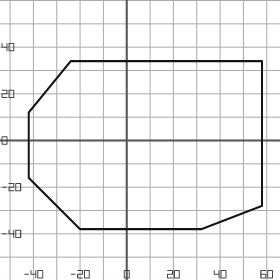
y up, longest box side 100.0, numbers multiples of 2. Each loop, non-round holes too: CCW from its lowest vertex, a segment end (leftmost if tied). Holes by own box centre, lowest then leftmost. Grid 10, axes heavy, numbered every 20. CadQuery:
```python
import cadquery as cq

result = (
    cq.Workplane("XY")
    .moveTo(-20.0, -38.0)
    .lineTo(32.0, -38.0)
    .lineTo(58.0, -28.0)
    .lineTo(58.0, 34.0)
    .lineTo(-24.0, 34.0)
    .lineTo(-42.0, 12.0)
    .lineTo(-42.0, -16.0)
    .close()
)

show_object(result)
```